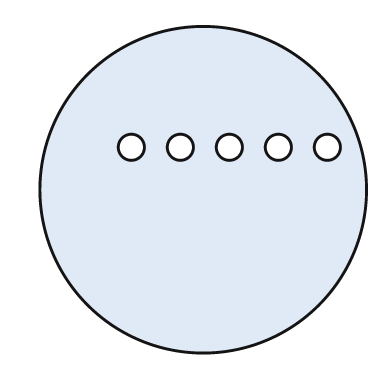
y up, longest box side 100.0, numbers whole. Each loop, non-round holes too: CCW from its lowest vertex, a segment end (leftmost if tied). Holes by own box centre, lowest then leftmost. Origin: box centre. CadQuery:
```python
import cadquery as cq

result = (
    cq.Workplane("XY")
    .moveTo(0.0, 0.0)
    .circle(50.0)
    .moveTo(-22.0, 13.0)
    .circle(4.0)
    .moveTo(-7.0, 13.0)
    .circle(4.0)
    .moveTo(8.0, 13.0)
    .circle(4.0)
    .moveTo(23.0, 13.0)
    .circle(4.0)
    .moveTo(38.0, 13.0)
    .circle(4.0)
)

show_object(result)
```